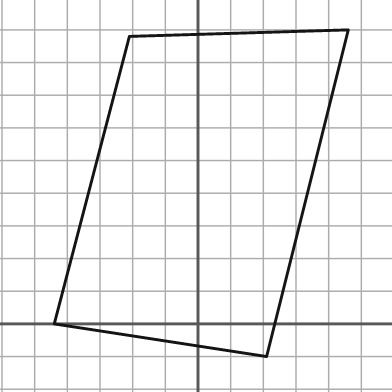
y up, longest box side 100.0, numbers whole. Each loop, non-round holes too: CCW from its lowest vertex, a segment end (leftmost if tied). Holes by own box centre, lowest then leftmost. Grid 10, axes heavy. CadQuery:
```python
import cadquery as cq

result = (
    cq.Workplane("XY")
    .moveTo(21.0, -10.0)
    .lineTo(46.0, 90.0)
    .lineTo(-21.0, 88.0)
    .lineTo(-44.0, 0.0)
    .close()
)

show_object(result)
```